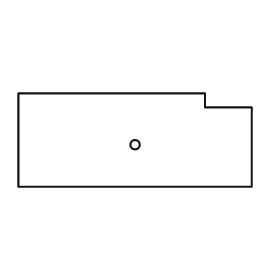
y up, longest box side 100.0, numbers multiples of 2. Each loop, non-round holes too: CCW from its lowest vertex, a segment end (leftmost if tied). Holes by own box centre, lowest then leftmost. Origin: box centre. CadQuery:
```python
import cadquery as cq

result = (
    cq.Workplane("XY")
    .moveTo(-50.0, -20.0)
    .lineTo(50.0, -20.0)
    .lineTo(50.0, 14.0)
    .lineTo(30.0, 14.0)
    .lineTo(30.0, 20.0)
    .lineTo(-50.0, 20.0)
    .close()
    .moveTo(0.0, -2.0)
    .circle(2.0)
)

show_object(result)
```